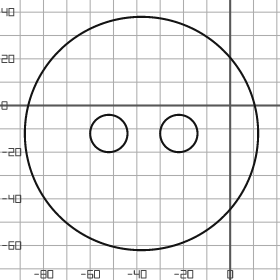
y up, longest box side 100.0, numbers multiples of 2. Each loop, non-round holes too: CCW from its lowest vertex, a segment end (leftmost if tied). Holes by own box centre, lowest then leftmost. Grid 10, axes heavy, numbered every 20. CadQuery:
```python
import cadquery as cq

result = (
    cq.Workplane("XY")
    .moveTo(-38.0, -12.0)
    .circle(50.0)
    .moveTo(-52.0, -12.0)
    .circle(8.0)
    .moveTo(-22.0, -12.0)
    .circle(8.0)
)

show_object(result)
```